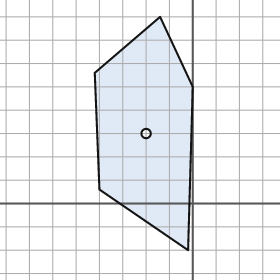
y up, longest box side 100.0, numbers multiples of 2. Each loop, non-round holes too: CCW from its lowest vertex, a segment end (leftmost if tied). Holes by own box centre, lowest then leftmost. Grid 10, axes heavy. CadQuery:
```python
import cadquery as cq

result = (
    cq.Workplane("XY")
    .moveTo(-2.0, -20.0)
    .lineTo(0.0, 50.0)
    .lineTo(-14.0, 80.0)
    .lineTo(-42.0, 56.0)
    .lineTo(-40.0, 6.0)
    .close()
    .moveTo(-20.0, 30.0)
    .circle(2.0)
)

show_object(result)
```